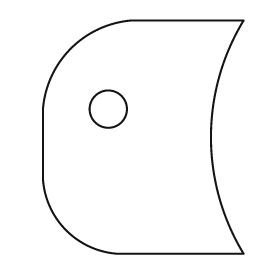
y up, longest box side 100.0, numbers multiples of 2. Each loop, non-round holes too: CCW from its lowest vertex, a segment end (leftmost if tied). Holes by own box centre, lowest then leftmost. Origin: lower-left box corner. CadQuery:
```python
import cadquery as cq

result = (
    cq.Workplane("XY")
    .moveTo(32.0, 0.0)
    .lineTo(86.0, 0.0)
    .threePointArc((72.0, 50.0), (86.0, 100.0))
    .lineTo(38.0, 100.0)
    .threePointArc((12.0, 88.0), (0.0, 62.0))
    .lineTo(0.0, 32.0)
    .threePointArc((10.0, 10.0), (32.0, 0.0))
    .close()
    .moveTo(28.0, 62.0)
    .circle(8.0)
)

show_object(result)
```